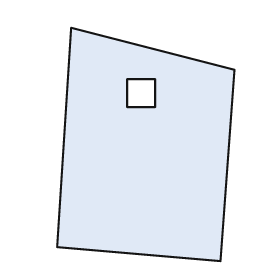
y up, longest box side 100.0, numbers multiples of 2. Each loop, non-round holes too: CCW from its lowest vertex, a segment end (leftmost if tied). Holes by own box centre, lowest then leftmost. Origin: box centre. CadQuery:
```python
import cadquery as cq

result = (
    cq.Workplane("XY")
    .moveTo(32.0, -50.0)
    .lineTo(38.0, 32.0)
    .lineTo(-32.0, 50.0)
    .lineTo(-38.0, -44.0)
    .close()
    .moveTo(-8.0, 16.0)
    .lineTo(4.0, 16.0)
    .lineTo(4.0, 28.0)
    .lineTo(-8.0, 28.0)
    .close()
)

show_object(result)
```